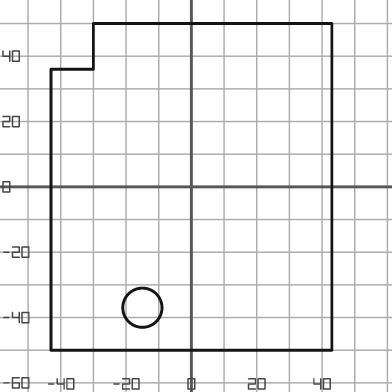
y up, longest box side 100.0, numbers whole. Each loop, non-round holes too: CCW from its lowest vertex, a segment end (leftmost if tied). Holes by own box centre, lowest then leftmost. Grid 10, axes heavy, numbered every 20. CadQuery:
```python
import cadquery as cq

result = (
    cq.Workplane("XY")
    .moveTo(-43.0, -50.0)
    .lineTo(43.0, -50.0)
    .lineTo(43.0, 50.0)
    .lineTo(-30.0, 50.0)
    .lineTo(-30.0, 36.0)
    .lineTo(-43.0, 36.0)
    .close()
    .moveTo(-15.0, -37.0)
    .circle(6.0)
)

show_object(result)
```